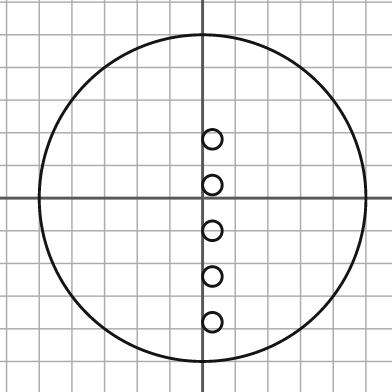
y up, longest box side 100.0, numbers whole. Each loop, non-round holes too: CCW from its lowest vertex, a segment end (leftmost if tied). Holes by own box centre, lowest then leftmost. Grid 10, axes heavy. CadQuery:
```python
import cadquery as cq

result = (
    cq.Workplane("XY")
    .moveTo(0.0, 0.0)
    .circle(50.0)
    .moveTo(3.0, -38.0)
    .circle(3.0)
    .moveTo(3.0, -24.0)
    .circle(3.0)
    .moveTo(3.0, -10.0)
    .circle(3.0)
    .moveTo(3.0, 4.0)
    .circle(3.0)
    .moveTo(3.0, 18.0)
    .circle(3.0)
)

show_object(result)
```